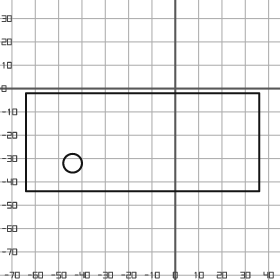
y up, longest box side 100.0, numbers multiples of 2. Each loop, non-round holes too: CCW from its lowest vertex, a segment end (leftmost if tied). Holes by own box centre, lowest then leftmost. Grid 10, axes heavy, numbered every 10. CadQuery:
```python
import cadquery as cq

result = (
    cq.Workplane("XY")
    .moveTo(-64.0, -44.0)
    .lineTo(36.0, -44.0)
    .lineTo(36.0, -2.0)
    .lineTo(-64.0, -2.0)
    .close()
    .moveTo(-44.0, -32.0)
    .circle(4.0)
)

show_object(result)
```